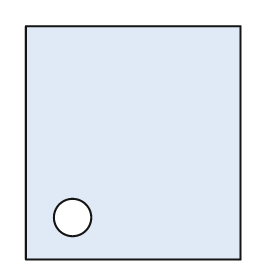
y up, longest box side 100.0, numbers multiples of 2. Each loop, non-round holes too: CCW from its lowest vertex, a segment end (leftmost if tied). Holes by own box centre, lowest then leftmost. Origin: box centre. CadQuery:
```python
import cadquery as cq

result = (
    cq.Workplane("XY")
    .moveTo(-46.0, -50.0)
    .lineTo(46.0, -50.0)
    .lineTo(46.0, 50.0)
    .lineTo(-46.0, 50.0)
    .close()
    .moveTo(-26.0, -32.0)
    .circle(8.0)
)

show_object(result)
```